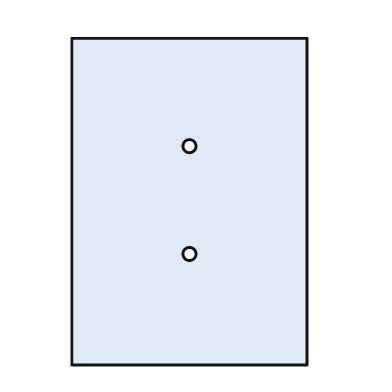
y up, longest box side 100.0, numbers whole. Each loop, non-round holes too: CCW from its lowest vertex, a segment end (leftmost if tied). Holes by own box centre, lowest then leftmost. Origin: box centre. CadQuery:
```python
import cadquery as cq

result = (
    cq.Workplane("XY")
    .moveTo(-36.0, -50.0)
    .lineTo(36.0, -50.0)
    .lineTo(36.0, 50.0)
    .lineTo(-36.0, 50.0)
    .close()
    .moveTo(0.0, -16.0)
    .circle(2.0)
    .moveTo(0.0, 17.0)
    .circle(2.0)
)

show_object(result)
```